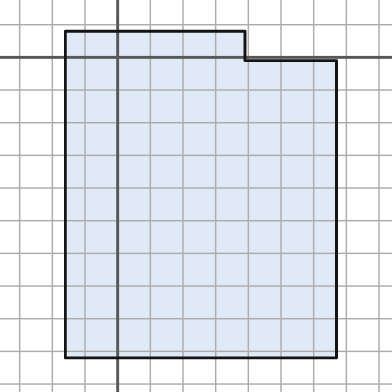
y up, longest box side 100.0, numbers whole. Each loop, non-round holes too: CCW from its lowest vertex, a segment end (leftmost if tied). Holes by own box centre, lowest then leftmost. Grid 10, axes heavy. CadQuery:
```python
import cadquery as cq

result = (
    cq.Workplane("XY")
    .moveTo(-16.0, -92.0)
    .lineTo(67.0, -92.0)
    .lineTo(67.0, -1.0)
    .lineTo(39.0, -1.0)
    .lineTo(39.0, 8.0)
    .lineTo(-16.0, 8.0)
    .close()
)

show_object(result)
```